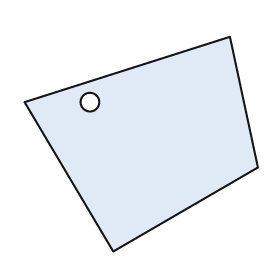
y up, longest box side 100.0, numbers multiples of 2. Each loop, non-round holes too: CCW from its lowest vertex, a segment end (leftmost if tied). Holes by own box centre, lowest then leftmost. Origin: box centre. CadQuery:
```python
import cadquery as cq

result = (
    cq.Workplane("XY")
    .moveTo(-12.0, -46.0)
    .lineTo(50.0, -10.0)
    .lineTo(38.0, 46.0)
    .lineTo(-50.0, 18.0)
    .close()
    .moveTo(-22.0, 18.0)
    .circle(4.0)
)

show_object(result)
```